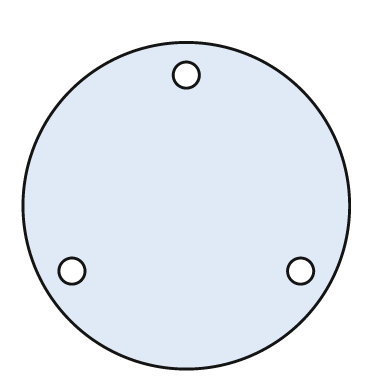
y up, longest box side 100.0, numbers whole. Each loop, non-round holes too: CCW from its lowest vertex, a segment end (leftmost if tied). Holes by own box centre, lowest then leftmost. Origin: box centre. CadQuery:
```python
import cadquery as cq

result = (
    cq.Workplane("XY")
    .moveTo(0.0, 0.0)
    .circle(50.0)
    .moveTo(-35.0, -20.0)
    .circle(4.0)
    .moveTo(35.0, -20.0)
    .circle(4.0)
    .moveTo(0.0, 40.0)
    .circle(4.0)
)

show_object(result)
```